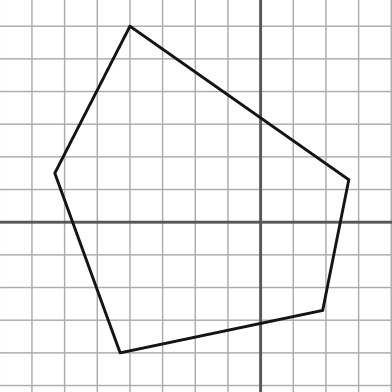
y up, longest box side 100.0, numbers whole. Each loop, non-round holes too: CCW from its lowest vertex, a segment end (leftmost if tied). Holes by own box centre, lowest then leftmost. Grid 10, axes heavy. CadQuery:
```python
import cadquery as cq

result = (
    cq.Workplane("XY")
    .moveTo(-43.0, -40.0)
    .lineTo(19.0, -27.0)
    .lineTo(27.0, 13.0)
    .lineTo(-40.0, 60.0)
    .lineTo(-63.0, 15.0)
    .close()
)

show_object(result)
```